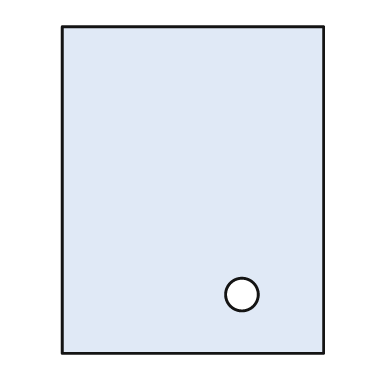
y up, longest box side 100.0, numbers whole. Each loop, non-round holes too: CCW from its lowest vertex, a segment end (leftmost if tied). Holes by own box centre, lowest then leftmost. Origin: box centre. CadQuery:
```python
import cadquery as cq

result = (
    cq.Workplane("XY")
    .moveTo(-40.0, -50.0)
    .lineTo(40.0, -50.0)
    .lineTo(40.0, 50.0)
    .lineTo(-40.0, 50.0)
    .close()
    .moveTo(15.0, -32.0)
    .circle(5.0)
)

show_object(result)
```